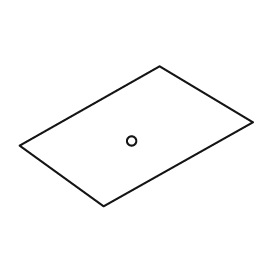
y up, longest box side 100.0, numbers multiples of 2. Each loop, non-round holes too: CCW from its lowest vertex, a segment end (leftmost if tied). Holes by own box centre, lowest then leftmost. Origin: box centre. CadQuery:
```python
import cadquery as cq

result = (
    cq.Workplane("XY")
    .moveTo(-14.0, -30.0)
    .lineTo(50.0, 6.0)
    .lineTo(10.0, 30.0)
    .lineTo(-50.0, -4.0)
    .close()
    .moveTo(-2.0, -2.0)
    .circle(2.0)
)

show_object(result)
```